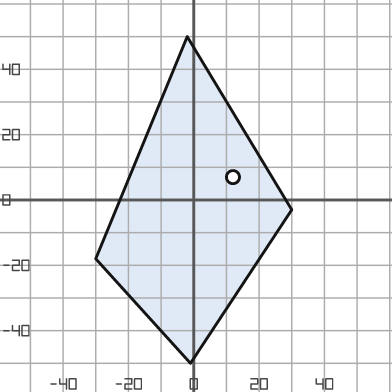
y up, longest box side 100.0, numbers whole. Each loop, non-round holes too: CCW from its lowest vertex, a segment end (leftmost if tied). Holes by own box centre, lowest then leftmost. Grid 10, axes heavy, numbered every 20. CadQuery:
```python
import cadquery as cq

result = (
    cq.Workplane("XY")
    .moveTo(-1.0, -50.0)
    .lineTo(30.0, -3.0)
    .lineTo(-2.0, 50.0)
    .lineTo(-30.0, -18.0)
    .close()
    .moveTo(12.0, 7.0)
    .circle(2.0)
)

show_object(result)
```